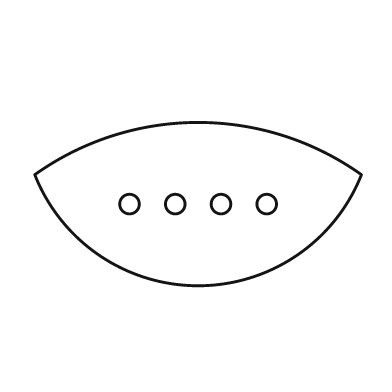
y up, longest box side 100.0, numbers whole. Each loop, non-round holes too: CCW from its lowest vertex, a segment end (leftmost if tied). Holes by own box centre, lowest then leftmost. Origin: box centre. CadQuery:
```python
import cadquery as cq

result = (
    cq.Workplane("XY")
    .moveTo(-50.0, 9.0)
    .threePointArc((0.0, -25.0), (50.0, 9.0))
    .threePointArc((0.0, 25.0), (-50.0, 9.0))
    .close()
    .moveTo(-21.0, 0.0)
    .circle(3.0)
    .moveTo(-7.0, 0.0)
    .circle(3.0)
    .moveTo(7.0, 0.0)
    .circle(3.0)
    .moveTo(21.0, 0.0)
    .circle(3.0)
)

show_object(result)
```